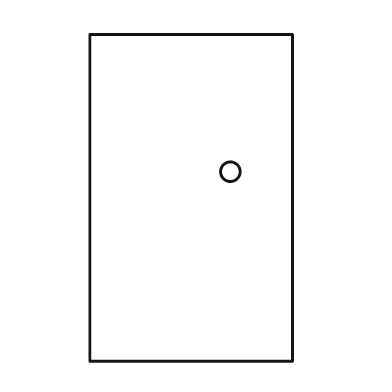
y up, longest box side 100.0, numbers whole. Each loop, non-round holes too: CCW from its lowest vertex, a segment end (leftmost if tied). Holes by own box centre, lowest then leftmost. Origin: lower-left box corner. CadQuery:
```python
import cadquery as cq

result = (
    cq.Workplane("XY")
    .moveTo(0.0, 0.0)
    .lineTo(62.0, 0.0)
    .lineTo(62.0, 100.0)
    .lineTo(0.0, 100.0)
    .close()
    .moveTo(43.0, 58.0)
    .circle(3.0)
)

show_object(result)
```